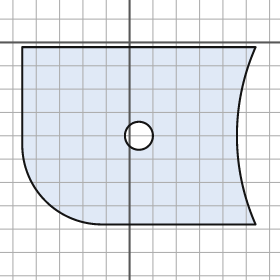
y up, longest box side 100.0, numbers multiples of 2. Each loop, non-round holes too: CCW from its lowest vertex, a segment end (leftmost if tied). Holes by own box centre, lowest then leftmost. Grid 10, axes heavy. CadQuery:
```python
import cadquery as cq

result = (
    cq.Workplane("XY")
    .moveTo(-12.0, -78.0)
    .lineTo(54.0, -78.0)
    .threePointArc((46.0, -40.0), (54.0, -2.0))
    .lineTo(-46.0, -2.0)
    .lineTo(-46.0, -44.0)
    .threePointArc((-36.0, -68.0), (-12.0, -78.0))
    .close()
    .moveTo(4.0, -40.0)
    .circle(6.0)
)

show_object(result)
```